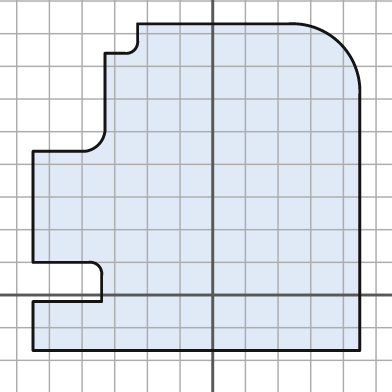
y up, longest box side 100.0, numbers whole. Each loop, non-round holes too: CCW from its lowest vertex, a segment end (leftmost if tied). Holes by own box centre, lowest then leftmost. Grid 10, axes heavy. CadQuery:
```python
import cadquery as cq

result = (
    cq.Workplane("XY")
    .moveTo(-55.0, -17.0)
    .lineTo(45.0, -17.0)
    .lineTo(45.0, 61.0)
    .threePointArc((39.0, 77.0), (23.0, 83.0))
    .lineTo(-23.0, 83.0)
    .lineTo(-23.0, 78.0)
    .threePointArc((-24.0, 75.0), (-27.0, 74.0))
    .lineTo(-33.0, 74.0)
    .lineTo(-33.0, 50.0)
    .threePointArc((-35.0, 46.0), (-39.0, 44.0))
    .lineTo(-55.0, 44.0)
    .lineTo(-55.0, 10.0)
    .lineTo(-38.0, 10.0)
    .threePointArc((-35.0, 9.0), (-34.0, 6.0))
    .lineTo(-34.0, -2.0)
    .lineTo(-55.0, -2.0)
    .close()
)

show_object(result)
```